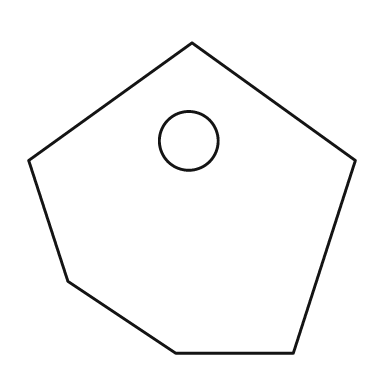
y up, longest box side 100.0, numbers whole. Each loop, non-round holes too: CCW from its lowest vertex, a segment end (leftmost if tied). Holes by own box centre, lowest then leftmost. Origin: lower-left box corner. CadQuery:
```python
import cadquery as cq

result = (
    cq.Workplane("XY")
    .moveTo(45.0, 0.0)
    .lineTo(81.0, 0.0)
    .lineTo(100.0, 59.0)
    .lineTo(50.0, 95.0)
    .lineTo(0.0, 59.0)
    .lineTo(12.0, 22.0)
    .close()
    .moveTo(49.0, 65.0)
    .circle(9.0)
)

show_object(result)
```